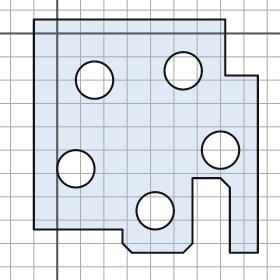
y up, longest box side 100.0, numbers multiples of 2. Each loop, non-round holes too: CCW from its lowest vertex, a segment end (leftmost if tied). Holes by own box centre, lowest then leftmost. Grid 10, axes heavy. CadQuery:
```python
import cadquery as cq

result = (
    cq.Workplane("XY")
    .moveTo(32.0, -94.0)
    .lineTo(54.0, -94.0)
    .lineTo(58.0, -90.0)
    .lineTo(58.0, -62.0)
    .lineTo(70.0, -62.0)
    .lineTo(74.0, -66.0)
    .lineTo(74.0, -94.0)
    .lineTo(86.0, -94.0)
    .lineTo(86.0, -18.0)
    .lineTo(72.0, -18.0)
    .lineTo(72.0, 6.0)
    .lineTo(-10.0, 6.0)
    .lineTo(-10.0, -84.0)
    .lineTo(28.0, -84.0)
    .lineTo(28.0, -90.0)
    .close()
    .moveTo(42.0, -76.0)
    .circle(8.0)
    .moveTo(8.0, -58.0)
    .circle(8.0)
    .moveTo(70.0, -50.0)
    .circle(8.0)
    .moveTo(16.0, -20.0)
    .circle(8.0)
    .moveTo(54.0, -16.0)
    .circle(8.0)
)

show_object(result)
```